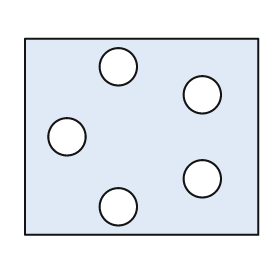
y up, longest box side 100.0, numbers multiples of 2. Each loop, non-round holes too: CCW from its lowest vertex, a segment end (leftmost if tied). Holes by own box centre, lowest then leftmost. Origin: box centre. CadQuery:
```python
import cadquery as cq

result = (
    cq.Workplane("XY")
    .moveTo(-50.0, -42.0)
    .lineTo(50.0, -42.0)
    .lineTo(50.0, 42.0)
    .lineTo(-50.0, 42.0)
    .close()
    .moveTo(-10.0, -30.0)
    .circle(8.0)
    .moveTo(26.0, -18.0)
    .circle(8.0)
    .moveTo(-32.0, 0.0)
    .circle(8.0)
    .moveTo(26.0, 18.0)
    .circle(8.0)
    .moveTo(-10.0, 30.0)
    .circle(8.0)
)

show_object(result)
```